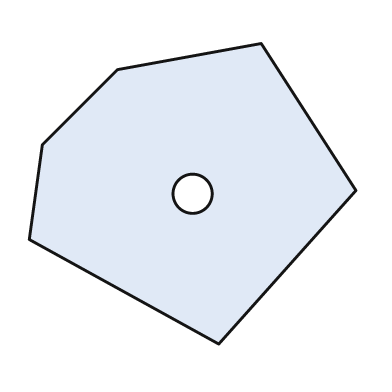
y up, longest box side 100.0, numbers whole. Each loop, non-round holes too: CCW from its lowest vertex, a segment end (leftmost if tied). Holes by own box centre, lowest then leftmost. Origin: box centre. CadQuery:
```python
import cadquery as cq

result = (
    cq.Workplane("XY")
    .moveTo(8.0, -46.0)
    .lineTo(50.0, 1.0)
    .lineTo(21.0, 46.0)
    .lineTo(-23.0, 38.0)
    .lineTo(-46.0, 15.0)
    .lineTo(-50.0, -14.0)
    .close()
    .moveTo(0.0, 0.0)
    .circle(6.0)
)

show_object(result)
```